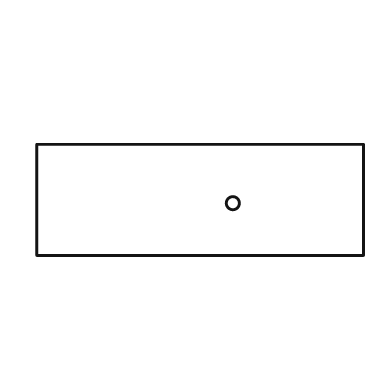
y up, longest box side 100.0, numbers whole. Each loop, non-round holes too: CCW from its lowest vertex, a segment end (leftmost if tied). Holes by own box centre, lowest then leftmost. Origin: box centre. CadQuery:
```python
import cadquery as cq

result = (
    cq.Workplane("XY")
    .moveTo(-50.0, -17.0)
    .lineTo(50.0, -17.0)
    .lineTo(50.0, 17.0)
    .lineTo(-50.0, 17.0)
    .close()
    .moveTo(10.0, -1.0)
    .circle(2.0)
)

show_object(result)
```